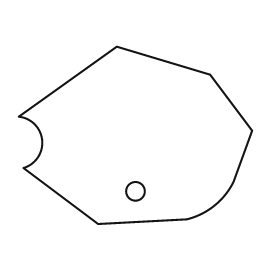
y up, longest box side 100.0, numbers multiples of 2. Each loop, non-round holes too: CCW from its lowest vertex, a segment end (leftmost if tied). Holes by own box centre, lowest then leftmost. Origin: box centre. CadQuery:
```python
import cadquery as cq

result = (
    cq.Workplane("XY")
    .moveTo(-16.0, -38.0)
    .lineTo(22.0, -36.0)
    .threePointArc((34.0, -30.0), (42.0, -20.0))
    .lineTo(50.0, 2.0)
    .lineTo(32.0, 26.0)
    .lineTo(-8.0, 38.0)
    .lineTo(-50.0, 8.0)
    .threePointArc((-40.0, -2.0), (-48.0, -14.0))
    .close()
    .moveTo(0.0, -24.0)
    .circle(4.0)
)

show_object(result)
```